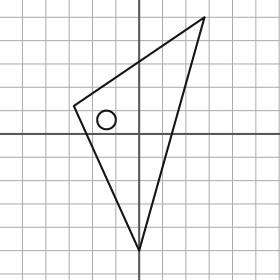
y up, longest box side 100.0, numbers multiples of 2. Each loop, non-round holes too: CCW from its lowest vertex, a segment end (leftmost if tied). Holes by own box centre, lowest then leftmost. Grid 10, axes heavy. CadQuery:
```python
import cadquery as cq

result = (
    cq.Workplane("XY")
    .moveTo(0.0, -50.0)
    .lineTo(28.0, 50.0)
    .lineTo(-28.0, 12.0)
    .close()
    .moveTo(-14.0, 6.0)
    .circle(4.0)
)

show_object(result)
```